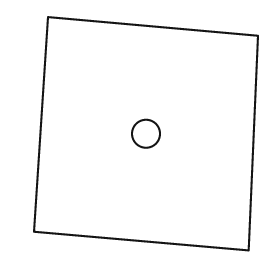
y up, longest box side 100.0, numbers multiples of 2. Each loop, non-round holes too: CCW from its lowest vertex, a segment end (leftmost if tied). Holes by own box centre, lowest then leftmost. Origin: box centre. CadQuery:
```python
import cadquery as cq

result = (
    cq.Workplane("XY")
    .moveTo(44.0, -50.0)
    .lineTo(48.0, 42.0)
    .lineTo(-42.0, 50.0)
    .lineTo(-48.0, -42.0)
    .close()
    .moveTo(0.0, 0.0)
    .circle(6.0)
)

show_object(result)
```